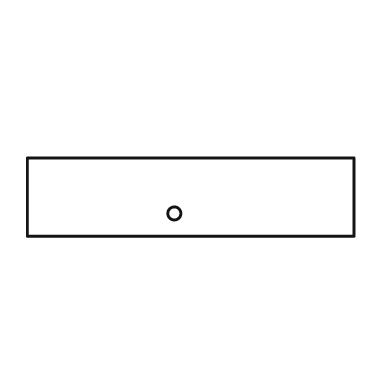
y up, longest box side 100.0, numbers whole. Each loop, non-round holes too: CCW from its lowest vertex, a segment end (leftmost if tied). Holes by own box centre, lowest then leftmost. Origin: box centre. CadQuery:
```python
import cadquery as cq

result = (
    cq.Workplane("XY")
    .moveTo(-50.0, -12.0)
    .lineTo(50.0, -12.0)
    .lineTo(50.0, 12.0)
    .lineTo(-50.0, 12.0)
    .close()
    .moveTo(-5.0, -5.0)
    .circle(2.0)
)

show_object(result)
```